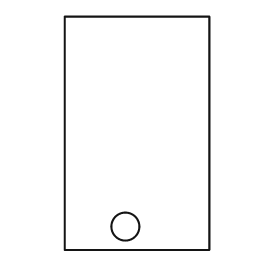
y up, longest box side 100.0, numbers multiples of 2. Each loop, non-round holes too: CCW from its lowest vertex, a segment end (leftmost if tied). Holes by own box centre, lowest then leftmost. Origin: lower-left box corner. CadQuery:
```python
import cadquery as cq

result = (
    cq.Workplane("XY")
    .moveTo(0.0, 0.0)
    .lineTo(62.0, 0.0)
    .lineTo(62.0, 100.0)
    .lineTo(0.0, 100.0)
    .close()
    .moveTo(26.0, 10.0)
    .circle(6.0)
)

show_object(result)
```